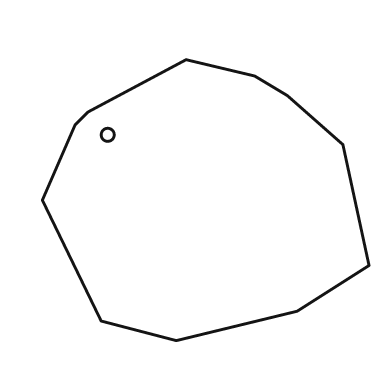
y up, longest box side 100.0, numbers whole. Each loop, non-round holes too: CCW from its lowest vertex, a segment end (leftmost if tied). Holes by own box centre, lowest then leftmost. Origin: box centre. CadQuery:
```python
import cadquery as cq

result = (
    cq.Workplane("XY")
    .moveTo(-9.0, -43.0)
    .lineTo(28.0, -34.0)
    .lineTo(50.0, -20.0)
    .lineTo(42.0, 17.0)
    .lineTo(25.0, 32.0)
    .lineTo(15.0, 38.0)
    .lineTo(-6.0, 43.0)
    .lineTo(-36.0, 27.0)
    .lineTo(-40.0, 23.0)
    .lineTo(-50.0, 0.0)
    .lineTo(-32.0, -37.0)
    .close()
    .moveTo(-30.0, 20.0)
    .circle(2.0)
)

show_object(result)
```